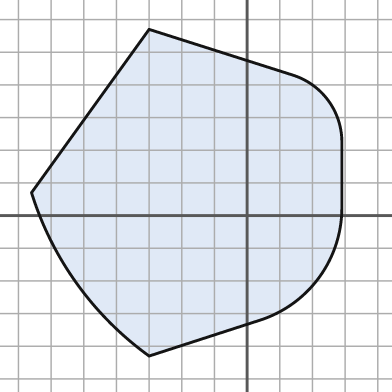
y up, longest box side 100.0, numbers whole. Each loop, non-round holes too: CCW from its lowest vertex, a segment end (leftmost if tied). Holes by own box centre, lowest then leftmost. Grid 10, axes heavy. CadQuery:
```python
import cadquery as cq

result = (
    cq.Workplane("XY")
    .moveTo(-30.0, -43.0)
    .lineTo(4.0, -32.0)
    .threePointArc((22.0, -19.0), (29.0, 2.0))
    .lineTo(29.0, 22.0)
    .threePointArc((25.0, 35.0), (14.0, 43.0))
    .lineTo(-30.0, 57.0)
    .lineTo(-66.0, 7.0)
    .threePointArc((-52.0, -21.0), (-30.0, -43.0))
    .close()
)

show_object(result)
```